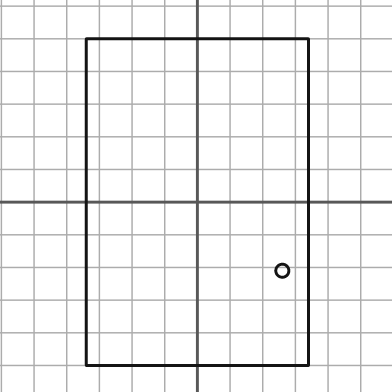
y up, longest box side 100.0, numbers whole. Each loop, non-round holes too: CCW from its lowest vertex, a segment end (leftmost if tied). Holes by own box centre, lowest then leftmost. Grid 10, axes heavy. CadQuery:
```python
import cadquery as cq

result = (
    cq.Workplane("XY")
    .moveTo(-34.0, -50.0)
    .lineTo(34.0, -50.0)
    .lineTo(34.0, 50.0)
    .lineTo(-34.0, 50.0)
    .close()
    .moveTo(26.0, -21.0)
    .circle(2.0)
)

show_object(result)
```